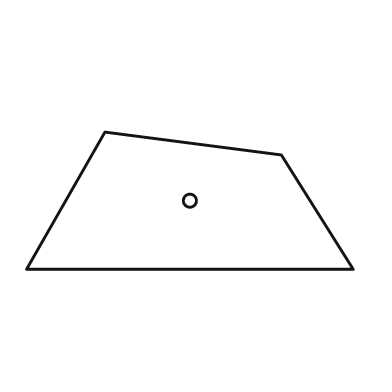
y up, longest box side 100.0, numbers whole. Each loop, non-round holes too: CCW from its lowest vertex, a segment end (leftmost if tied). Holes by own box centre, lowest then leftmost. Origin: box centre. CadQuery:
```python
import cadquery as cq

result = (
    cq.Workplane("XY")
    .moveTo(-50.0, -21.0)
    .lineTo(50.0, -21.0)
    .lineTo(28.0, 14.0)
    .lineTo(-26.0, 21.0)
    .close()
    .moveTo(0.0, 0.0)
    .circle(2.0)
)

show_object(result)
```